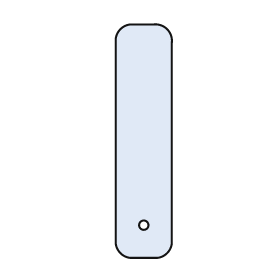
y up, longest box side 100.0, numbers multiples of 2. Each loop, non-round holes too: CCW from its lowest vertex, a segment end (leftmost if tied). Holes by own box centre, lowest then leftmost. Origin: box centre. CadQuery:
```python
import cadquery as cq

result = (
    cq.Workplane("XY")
    .moveTo(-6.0, -50.0)
    .lineTo(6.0, -50.0)
    .threePointArc((10.0, -48.0), (12.0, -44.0))
    .lineTo(12.0, 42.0)
    .threePointArc((10.0, 48.0), (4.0, 50.0))
    .lineTo(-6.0, 50.0)
    .threePointArc((-10.0, 48.0), (-12.0, 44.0))
    .lineTo(-12.0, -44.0)
    .threePointArc((-10.0, -48.0), (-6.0, -50.0))
    .close()
    .moveTo(0.0, -36.0)
    .circle(2.0)
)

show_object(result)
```